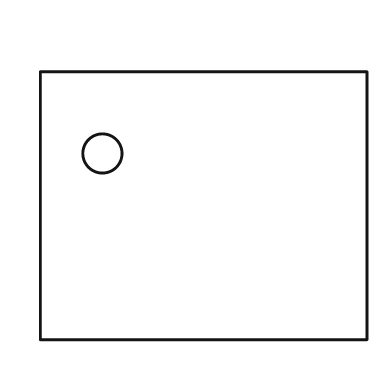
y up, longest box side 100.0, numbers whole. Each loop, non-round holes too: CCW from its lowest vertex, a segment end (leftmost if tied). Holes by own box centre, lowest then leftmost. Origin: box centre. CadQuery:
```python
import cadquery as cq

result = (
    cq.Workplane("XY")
    .moveTo(-50.0, -41.0)
    .lineTo(50.0, -41.0)
    .lineTo(50.0, 41.0)
    .lineTo(-50.0, 41.0)
    .close()
    .moveTo(-31.0, 16.0)
    .circle(6.0)
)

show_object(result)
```